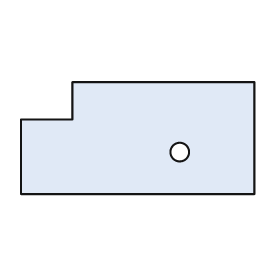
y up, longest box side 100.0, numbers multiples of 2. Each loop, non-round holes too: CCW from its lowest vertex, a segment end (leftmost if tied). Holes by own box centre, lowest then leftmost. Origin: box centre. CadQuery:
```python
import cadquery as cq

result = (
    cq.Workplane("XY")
    .moveTo(-50.0, -24.0)
    .lineTo(50.0, -24.0)
    .lineTo(50.0, 24.0)
    .lineTo(-28.0, 24.0)
    .lineTo(-28.0, 8.0)
    .lineTo(-50.0, 8.0)
    .close()
    .moveTo(18.0, -6.0)
    .circle(4.0)
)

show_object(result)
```